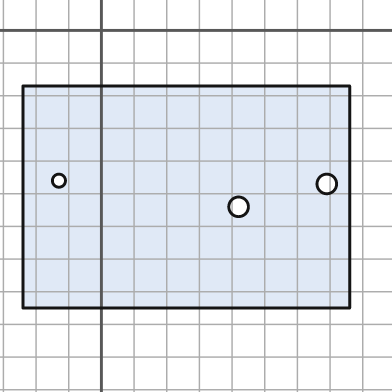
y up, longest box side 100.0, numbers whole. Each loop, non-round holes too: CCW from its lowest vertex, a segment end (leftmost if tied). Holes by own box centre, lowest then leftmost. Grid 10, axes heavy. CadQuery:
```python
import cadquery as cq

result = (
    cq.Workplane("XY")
    .moveTo(-24.0, -85.0)
    .lineTo(76.0, -85.0)
    .lineTo(76.0, -17.0)
    .lineTo(-24.0, -17.0)
    .close()
    .moveTo(42.0, -54.0)
    .circle(3.0)
    .moveTo(69.0, -47.0)
    .circle(3.0)
    .moveTo(-13.0, -46.0)
    .circle(2.0)
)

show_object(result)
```